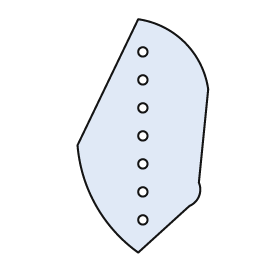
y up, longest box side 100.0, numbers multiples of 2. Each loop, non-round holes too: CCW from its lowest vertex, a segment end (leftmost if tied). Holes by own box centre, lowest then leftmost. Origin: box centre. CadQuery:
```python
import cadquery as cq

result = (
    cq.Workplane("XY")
    .moveTo(-2.0, -50.0)
    .lineTo(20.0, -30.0)
    .threePointArc((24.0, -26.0), (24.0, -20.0))
    .lineTo(28.0, 20.0)
    .threePointArc((18.0, 40.0), (-2.0, 50.0))
    .lineTo(-28.0, -4.0)
    .threePointArc((-20.0, -30.0), (-2.0, -50.0))
    .close()
    .moveTo(0.0, -36.0)
    .circle(2.0)
    .moveTo(0.0, -24.0)
    .circle(2.0)
    .moveTo(0.0, -12.0)
    .circle(2.0)
    .moveTo(0.0, 0.0)
    .circle(2.0)
    .moveTo(0.0, 12.0)
    .circle(2.0)
    .moveTo(0.0, 24.0)
    .circle(2.0)
    .moveTo(0.0, 36.0)
    .circle(2.0)
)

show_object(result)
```